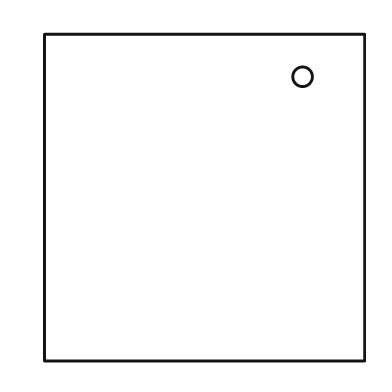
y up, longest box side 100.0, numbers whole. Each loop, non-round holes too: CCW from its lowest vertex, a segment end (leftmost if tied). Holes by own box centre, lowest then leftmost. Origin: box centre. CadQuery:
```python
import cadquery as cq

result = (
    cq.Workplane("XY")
    .moveTo(-49.0, -50.0)
    .lineTo(49.0, -50.0)
    .lineTo(49.0, 50.0)
    .lineTo(-49.0, 50.0)
    .close()
    .moveTo(30.0, 37.0)
    .circle(3.0)
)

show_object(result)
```